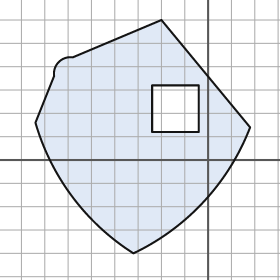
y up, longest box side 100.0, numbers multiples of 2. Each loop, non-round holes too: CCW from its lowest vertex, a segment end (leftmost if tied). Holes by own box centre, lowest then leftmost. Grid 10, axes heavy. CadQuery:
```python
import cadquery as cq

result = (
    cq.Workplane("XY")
    .moveTo(-32.0, -40.0)
    .threePointArc((-2.0, -18.0), (18.0, 14.0))
    .lineTo(-20.0, 60.0)
    .lineTo(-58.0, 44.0)
    .threePointArc((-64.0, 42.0), (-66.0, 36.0))
    .lineTo(-74.0, 16.0)
    .threePointArc((-58.0, -16.0), (-32.0, -40.0))
    .close()
    .moveTo(-24.0, 12.0)
    .lineTo(-4.0, 12.0)
    .lineTo(-4.0, 32.0)
    .lineTo(-24.0, 32.0)
    .close()
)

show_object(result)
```